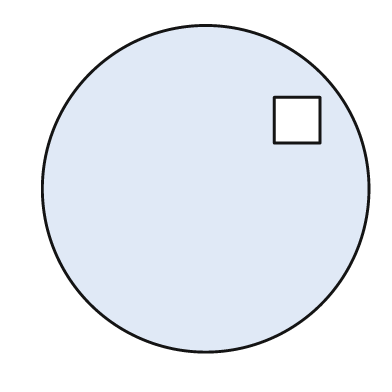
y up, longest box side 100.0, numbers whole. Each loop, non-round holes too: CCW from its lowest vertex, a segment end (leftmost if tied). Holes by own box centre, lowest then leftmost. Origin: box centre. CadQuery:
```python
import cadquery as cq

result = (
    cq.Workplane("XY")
    .moveTo(0.0, 0.0)
    .circle(50.0)
    .moveTo(21.0, 14.0)
    .lineTo(35.0, 14.0)
    .lineTo(35.0, 28.0)
    .lineTo(21.0, 28.0)
    .close()
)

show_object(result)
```